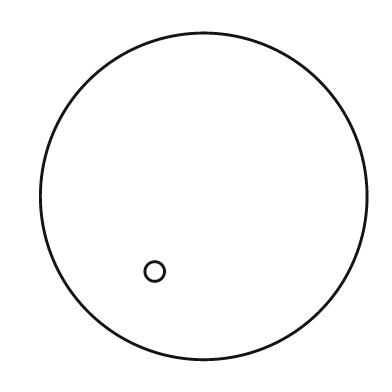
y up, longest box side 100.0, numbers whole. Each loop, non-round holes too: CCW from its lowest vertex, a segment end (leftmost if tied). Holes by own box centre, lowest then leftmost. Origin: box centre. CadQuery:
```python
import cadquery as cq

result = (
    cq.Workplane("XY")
    .moveTo(0.0, 0.0)
    .circle(50.0)
    .moveTo(-15.0, -23.0)
    .circle(3.0)
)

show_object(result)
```